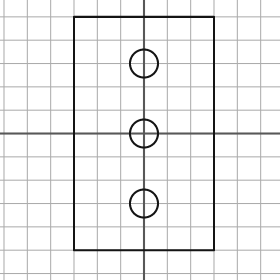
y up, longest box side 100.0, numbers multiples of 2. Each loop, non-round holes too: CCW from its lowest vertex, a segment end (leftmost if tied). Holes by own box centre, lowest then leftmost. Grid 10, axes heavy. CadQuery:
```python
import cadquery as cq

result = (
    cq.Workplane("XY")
    .moveTo(-30.0, -50.0)
    .lineTo(30.0, -50.0)
    .lineTo(30.0, 50.0)
    .lineTo(-30.0, 50.0)
    .close()
    .moveTo(0.0, -30.0)
    .circle(6.0)
    .moveTo(0.0, 0.0)
    .circle(6.0)
    .moveTo(0.0, 30.0)
    .circle(6.0)
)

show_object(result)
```